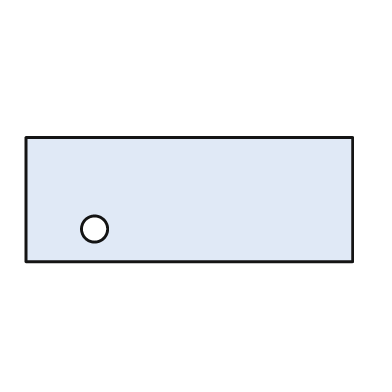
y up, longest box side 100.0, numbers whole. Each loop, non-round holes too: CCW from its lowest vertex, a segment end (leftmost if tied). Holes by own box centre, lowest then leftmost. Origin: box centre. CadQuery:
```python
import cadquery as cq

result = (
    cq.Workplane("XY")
    .moveTo(-50.0, -19.0)
    .lineTo(50.0, -19.0)
    .lineTo(50.0, 19.0)
    .lineTo(-50.0, 19.0)
    .close()
    .moveTo(-29.0, -9.0)
    .circle(4.0)
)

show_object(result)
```